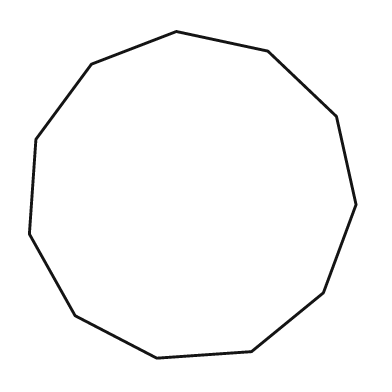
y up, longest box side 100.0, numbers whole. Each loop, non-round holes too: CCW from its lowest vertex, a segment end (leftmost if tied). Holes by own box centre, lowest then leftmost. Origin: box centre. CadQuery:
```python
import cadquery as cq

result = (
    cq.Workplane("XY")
    .moveTo(-11.0, -50.0)
    .lineTo(18.0, -48.0)
    .lineTo(40.0, -30.0)
    .lineTo(50.0, -3.0)
    .lineTo(44.0, 24.0)
    .lineTo(23.0, 44.0)
    .lineTo(-5.0, 50.0)
    .lineTo(-31.0, 40.0)
    .lineTo(-48.0, 17.0)
    .lineTo(-50.0, -12.0)
    .lineTo(-36.0, -37.0)
    .close()
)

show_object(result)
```